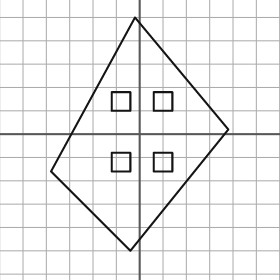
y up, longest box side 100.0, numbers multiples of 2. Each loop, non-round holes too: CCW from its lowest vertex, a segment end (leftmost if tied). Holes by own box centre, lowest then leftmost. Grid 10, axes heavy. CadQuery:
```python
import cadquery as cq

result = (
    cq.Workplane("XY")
    .moveTo(-4.0, -50.0)
    .lineTo(38.0, 2.0)
    .lineTo(-2.0, 50.0)
    .lineTo(-38.0, -16.0)
    .close()
    .moveTo(-12.0, -16.0)
    .lineTo(-4.0, -16.0)
    .lineTo(-4.0, -8.0)
    .lineTo(-12.0, -8.0)
    .close()
    .moveTo(6.0, -16.0)
    .lineTo(14.0, -16.0)
    .lineTo(14.0, -8.0)
    .lineTo(6.0, -8.0)
    .close()
    .moveTo(-12.0, 10.0)
    .lineTo(-4.0, 10.0)
    .lineTo(-4.0, 18.0)
    .lineTo(-12.0, 18.0)
    .close()
    .moveTo(6.0, 10.0)
    .lineTo(14.0, 10.0)
    .lineTo(14.0, 18.0)
    .lineTo(6.0, 18.0)
    .close()
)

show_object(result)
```